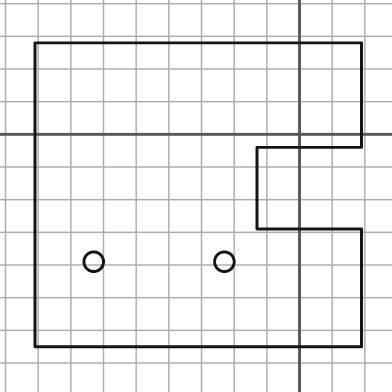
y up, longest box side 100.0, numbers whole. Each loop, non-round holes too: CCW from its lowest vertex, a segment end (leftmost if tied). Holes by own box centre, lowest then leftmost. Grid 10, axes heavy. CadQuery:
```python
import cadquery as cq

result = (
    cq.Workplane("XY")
    .moveTo(-81.0, -65.0)
    .lineTo(19.0, -65.0)
    .lineTo(19.0, -29.0)
    .lineTo(-13.0, -29.0)
    .lineTo(-13.0, -4.0)
    .lineTo(19.0, -4.0)
    .lineTo(19.0, 28.0)
    .lineTo(-81.0, 28.0)
    .close()
    .moveTo(-63.0, -39.0)
    .circle(3.0)
    .moveTo(-23.0, -39.0)
    .circle(3.0)
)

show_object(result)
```